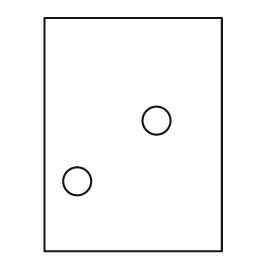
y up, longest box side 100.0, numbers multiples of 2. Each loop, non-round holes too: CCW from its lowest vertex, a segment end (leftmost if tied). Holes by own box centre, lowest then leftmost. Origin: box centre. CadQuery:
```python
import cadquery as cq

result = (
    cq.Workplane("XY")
    .moveTo(-38.0, -50.0)
    .lineTo(38.0, -50.0)
    .lineTo(38.0, 50.0)
    .lineTo(-38.0, 50.0)
    .close()
    .moveTo(-24.0, -20.0)
    .circle(6.0)
    .moveTo(10.0, 6.0)
    .circle(6.0)
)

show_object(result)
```